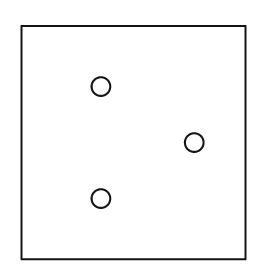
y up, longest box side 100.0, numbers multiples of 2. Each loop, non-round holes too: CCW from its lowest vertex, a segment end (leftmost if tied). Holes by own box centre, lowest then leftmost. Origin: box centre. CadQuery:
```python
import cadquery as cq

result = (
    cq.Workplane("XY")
    .moveTo(-48.0, -50.0)
    .lineTo(48.0, -50.0)
    .lineTo(48.0, 50.0)
    .lineTo(-48.0, 50.0)
    .close()
    .moveTo(-14.0, -24.0)
    .circle(4.0)
    .moveTo(26.0, 0.0)
    .circle(4.0)
    .moveTo(-14.0, 24.0)
    .circle(4.0)
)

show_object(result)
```